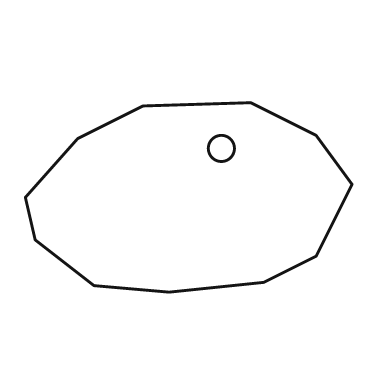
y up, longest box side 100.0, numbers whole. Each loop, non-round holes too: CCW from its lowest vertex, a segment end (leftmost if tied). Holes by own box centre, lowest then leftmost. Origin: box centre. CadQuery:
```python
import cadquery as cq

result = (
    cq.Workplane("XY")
    .moveTo(-6.0, -29.0)
    .lineTo(23.0, -26.0)
    .lineTo(39.0, -18.0)
    .lineTo(50.0, 4.0)
    .lineTo(39.0, 19.0)
    .lineTo(19.0, 29.0)
    .lineTo(-14.0, 28.0)
    .lineTo(-34.0, 18.0)
    .lineTo(-50.0, 0.0)
    .lineTo(-47.0, -13.0)
    .lineTo(-29.0, -27.0)
    .close()
    .moveTo(10.0, 15.0)
    .circle(4.0)
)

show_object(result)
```